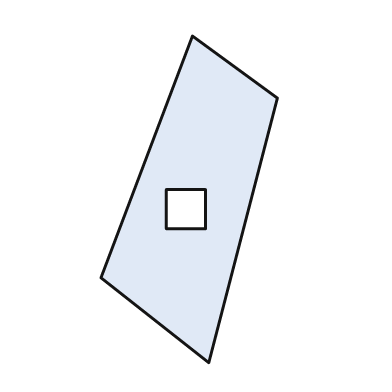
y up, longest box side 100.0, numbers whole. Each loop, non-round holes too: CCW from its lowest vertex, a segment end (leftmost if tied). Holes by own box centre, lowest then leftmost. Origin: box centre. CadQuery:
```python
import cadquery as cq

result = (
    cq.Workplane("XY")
    .moveTo(6.0, -50.0)
    .lineTo(27.0, 31.0)
    .lineTo(1.0, 50.0)
    .lineTo(-27.0, -24.0)
    .close()
    .moveTo(-7.0, -9.0)
    .lineTo(5.0, -9.0)
    .lineTo(5.0, 3.0)
    .lineTo(-7.0, 3.0)
    .close()
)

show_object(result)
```